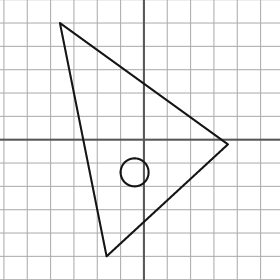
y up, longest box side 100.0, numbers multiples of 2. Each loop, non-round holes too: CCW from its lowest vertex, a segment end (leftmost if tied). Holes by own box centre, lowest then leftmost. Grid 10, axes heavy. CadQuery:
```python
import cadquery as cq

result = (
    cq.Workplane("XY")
    .moveTo(-16.0, -50.0)
    .lineTo(36.0, -2.0)
    .lineTo(-36.0, 50.0)
    .close()
    .moveTo(-4.0, -14.0)
    .circle(6.0)
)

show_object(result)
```